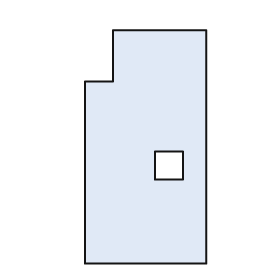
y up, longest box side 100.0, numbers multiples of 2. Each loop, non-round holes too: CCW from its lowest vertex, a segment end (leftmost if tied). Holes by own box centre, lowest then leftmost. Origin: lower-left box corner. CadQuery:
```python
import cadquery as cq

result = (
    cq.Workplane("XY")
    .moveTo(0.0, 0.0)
    .lineTo(52.0, 0.0)
    .lineTo(52.0, 100.0)
    .lineTo(12.0, 100.0)
    .lineTo(12.0, 78.0)
    .lineTo(0.0, 78.0)
    .close()
    .moveTo(30.0, 36.0)
    .lineTo(42.0, 36.0)
    .lineTo(42.0, 48.0)
    .lineTo(30.0, 48.0)
    .close()
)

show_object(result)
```